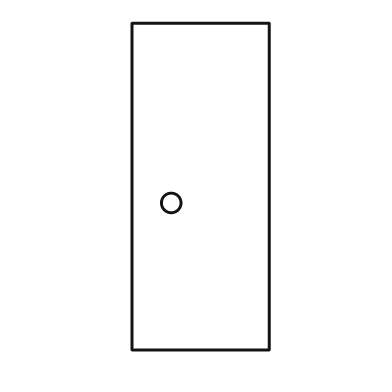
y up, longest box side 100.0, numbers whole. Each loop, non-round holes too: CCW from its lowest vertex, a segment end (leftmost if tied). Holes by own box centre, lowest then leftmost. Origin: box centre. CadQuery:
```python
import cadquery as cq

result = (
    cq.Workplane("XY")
    .moveTo(-21.0, -50.0)
    .lineTo(21.0, -50.0)
    .lineTo(21.0, 50.0)
    .lineTo(-21.0, 50.0)
    .close()
    .moveTo(-9.0, -5.0)
    .circle(3.0)
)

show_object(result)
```